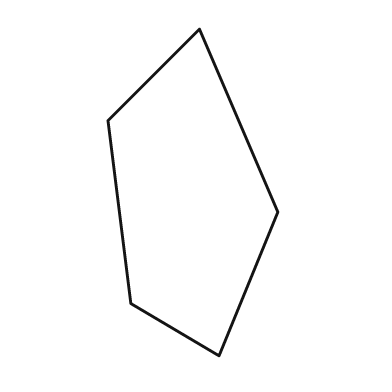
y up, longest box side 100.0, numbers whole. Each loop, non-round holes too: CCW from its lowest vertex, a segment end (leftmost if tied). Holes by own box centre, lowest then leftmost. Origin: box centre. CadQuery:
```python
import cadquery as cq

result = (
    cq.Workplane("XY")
    .moveTo(8.0, -50.0)
    .lineTo(26.0, -6.0)
    .lineTo(2.0, 50.0)
    .lineTo(-26.0, 22.0)
    .lineTo(-19.0, -34.0)
    .close()
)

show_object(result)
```